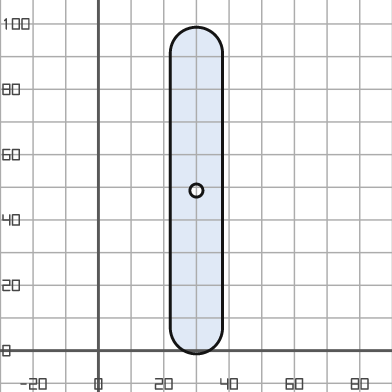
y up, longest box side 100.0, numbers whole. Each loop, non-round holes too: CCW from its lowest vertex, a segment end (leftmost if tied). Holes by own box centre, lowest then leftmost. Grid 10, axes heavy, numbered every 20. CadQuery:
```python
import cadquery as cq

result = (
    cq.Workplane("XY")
    .moveTo(22.0, 7.0)
    .threePointArc((30.0, -1.0), (38.0, 7.0))
    .lineTo(38.0, 91.0)
    .threePointArc((30.0, 99.0), (22.0, 91.0))
    .close()
    .moveTo(30.0, 49.0)
    .circle(2.0)
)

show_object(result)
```